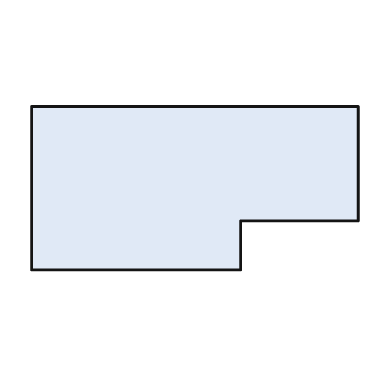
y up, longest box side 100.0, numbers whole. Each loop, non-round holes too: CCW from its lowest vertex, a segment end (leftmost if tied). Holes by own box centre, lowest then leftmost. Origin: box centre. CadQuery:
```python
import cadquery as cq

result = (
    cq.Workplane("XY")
    .moveTo(-50.0, -25.0)
    .lineTo(14.0, -25.0)
    .lineTo(14.0, -10.0)
    .lineTo(50.0, -10.0)
    .lineTo(50.0, 25.0)
    .lineTo(-50.0, 25.0)
    .close()
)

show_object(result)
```